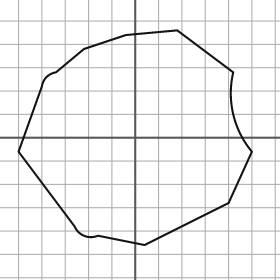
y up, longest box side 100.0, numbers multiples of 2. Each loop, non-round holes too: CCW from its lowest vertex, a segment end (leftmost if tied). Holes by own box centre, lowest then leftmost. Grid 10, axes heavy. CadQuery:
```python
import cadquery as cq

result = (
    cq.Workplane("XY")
    .moveTo(4.0, -46.0)
    .lineTo(40.0, -28.0)
    .lineTo(50.0, -6.0)
    .threePointArc((42.0, 10.0), (42.0, 28.0))
    .lineTo(18.0, 46.0)
    .lineTo(-4.0, 44.0)
    .lineTo(-22.0, 38.0)
    .lineTo(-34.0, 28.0)
    .threePointArc((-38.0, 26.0), (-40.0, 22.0))
    .lineTo(-50.0, -6.0)
    .lineTo(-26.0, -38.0)
    .threePointArc((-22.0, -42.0), (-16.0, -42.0))
    .close()
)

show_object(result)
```